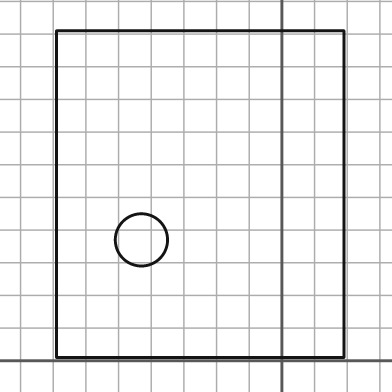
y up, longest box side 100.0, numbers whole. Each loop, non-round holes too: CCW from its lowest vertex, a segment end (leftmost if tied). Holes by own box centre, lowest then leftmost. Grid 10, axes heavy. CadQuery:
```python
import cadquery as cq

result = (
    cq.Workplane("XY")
    .moveTo(-69.0, 1.0)
    .lineTo(19.0, 1.0)
    .lineTo(19.0, 101.0)
    .lineTo(-69.0, 101.0)
    .close()
    .moveTo(-43.0, 37.0)
    .circle(8.0)
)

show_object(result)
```